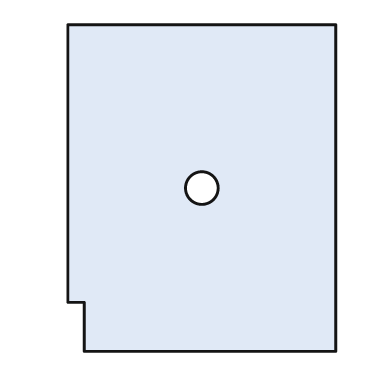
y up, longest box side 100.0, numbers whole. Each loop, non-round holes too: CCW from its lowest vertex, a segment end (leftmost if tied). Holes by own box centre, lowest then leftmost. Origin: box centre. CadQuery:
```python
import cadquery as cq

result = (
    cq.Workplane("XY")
    .moveTo(-36.0, -50.0)
    .lineTo(41.0, -50.0)
    .lineTo(41.0, 50.0)
    .lineTo(-41.0, 50.0)
    .lineTo(-41.0, -35.0)
    .lineTo(-36.0, -35.0)
    .close()
    .moveTo(0.0, 0.0)
    .circle(5.0)
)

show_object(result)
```